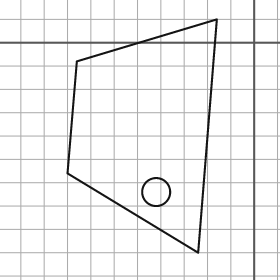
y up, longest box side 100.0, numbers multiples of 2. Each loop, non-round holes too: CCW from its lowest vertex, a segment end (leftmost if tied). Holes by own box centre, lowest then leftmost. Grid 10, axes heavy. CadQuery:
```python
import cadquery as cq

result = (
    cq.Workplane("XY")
    .moveTo(-24.0, -90.0)
    .lineTo(-16.0, 10.0)
    .lineTo(-76.0, -8.0)
    .lineTo(-80.0, -56.0)
    .close()
    .moveTo(-42.0, -64.0)
    .circle(6.0)
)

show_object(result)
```